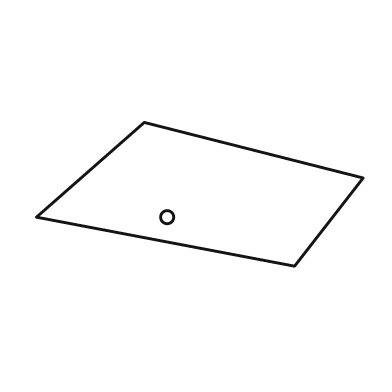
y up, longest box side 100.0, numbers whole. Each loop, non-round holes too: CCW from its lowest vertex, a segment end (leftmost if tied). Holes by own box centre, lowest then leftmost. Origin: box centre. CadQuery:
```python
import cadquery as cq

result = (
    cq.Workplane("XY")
    .moveTo(29.0, -22.0)
    .lineTo(50.0, 5.0)
    .lineTo(-17.0, 22.0)
    .lineTo(-50.0, -7.0)
    .close()
    .moveTo(-10.0, -7.0)
    .circle(2.0)
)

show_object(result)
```